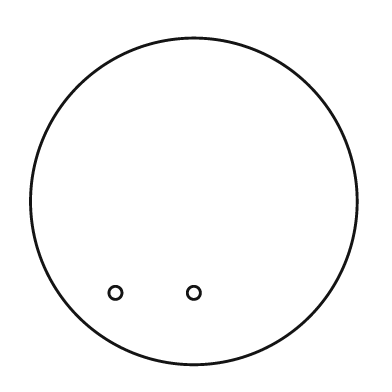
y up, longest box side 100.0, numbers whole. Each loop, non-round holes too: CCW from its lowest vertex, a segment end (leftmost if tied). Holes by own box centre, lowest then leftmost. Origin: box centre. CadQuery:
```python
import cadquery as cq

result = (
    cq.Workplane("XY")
    .moveTo(0.0, 0.0)
    .circle(50.0)
    .moveTo(-24.0, -28.0)
    .circle(2.0)
    .moveTo(0.0, -28.0)
    .circle(2.0)
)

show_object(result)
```